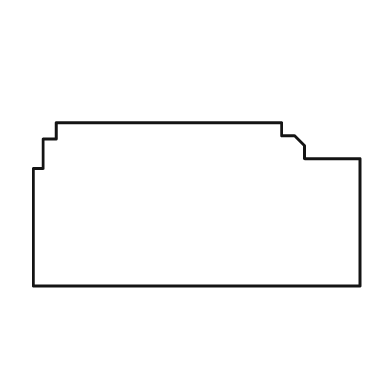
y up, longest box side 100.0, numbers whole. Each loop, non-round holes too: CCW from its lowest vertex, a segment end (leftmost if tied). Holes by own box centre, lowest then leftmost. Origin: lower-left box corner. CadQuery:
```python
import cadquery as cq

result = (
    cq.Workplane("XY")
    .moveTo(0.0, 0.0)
    .lineTo(100.0, 0.0)
    .lineTo(100.0, 39.0)
    .lineTo(83.0, 39.0)
    .lineTo(83.0, 43.0)
    .lineTo(80.0, 46.0)
    .lineTo(76.0, 46.0)
    .lineTo(76.0, 50.0)
    .lineTo(7.0, 50.0)
    .lineTo(7.0, 45.0)
    .lineTo(3.0, 45.0)
    .lineTo(3.0, 36.0)
    .lineTo(0.0, 36.0)
    .close()
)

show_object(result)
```